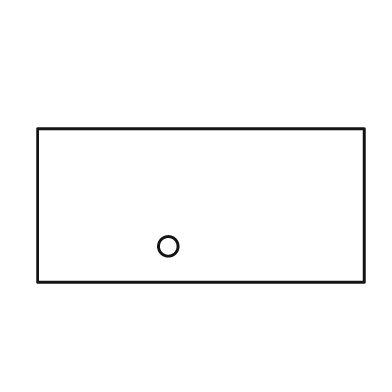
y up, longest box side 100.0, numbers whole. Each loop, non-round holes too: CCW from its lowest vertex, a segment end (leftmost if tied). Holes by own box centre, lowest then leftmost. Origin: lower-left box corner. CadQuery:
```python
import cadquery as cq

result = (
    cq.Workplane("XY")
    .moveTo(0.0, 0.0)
    .lineTo(100.0, 0.0)
    .lineTo(100.0, 47.0)
    .lineTo(0.0, 47.0)
    .close()
    .moveTo(40.0, 11.0)
    .circle(3.0)
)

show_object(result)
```